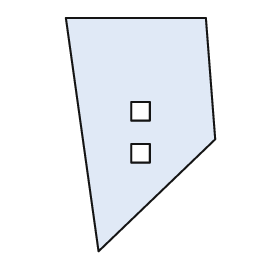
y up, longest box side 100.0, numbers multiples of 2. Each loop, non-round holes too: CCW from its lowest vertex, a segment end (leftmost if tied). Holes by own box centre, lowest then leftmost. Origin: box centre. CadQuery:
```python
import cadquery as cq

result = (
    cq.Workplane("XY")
    .moveTo(-18.0, -50.0)
    .lineTo(32.0, -2.0)
    .lineTo(28.0, 50.0)
    .lineTo(-32.0, 50.0)
    .close()
    .moveTo(-4.0, -12.0)
    .lineTo(4.0, -12.0)
    .lineTo(4.0, -4.0)
    .lineTo(-4.0, -4.0)
    .close()
    .moveTo(-4.0, 6.0)
    .lineTo(4.0, 6.0)
    .lineTo(4.0, 14.0)
    .lineTo(-4.0, 14.0)
    .close()
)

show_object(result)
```